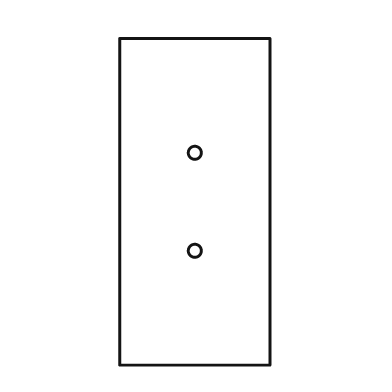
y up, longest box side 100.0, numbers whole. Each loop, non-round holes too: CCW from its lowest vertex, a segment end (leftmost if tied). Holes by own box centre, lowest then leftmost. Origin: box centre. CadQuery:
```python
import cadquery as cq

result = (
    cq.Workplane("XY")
    .moveTo(-23.0, -50.0)
    .lineTo(23.0, -50.0)
    .lineTo(23.0, 50.0)
    .lineTo(-23.0, 50.0)
    .close()
    .moveTo(0.0, -15.0)
    .circle(2.0)
    .moveTo(0.0, 15.0)
    .circle(2.0)
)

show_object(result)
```